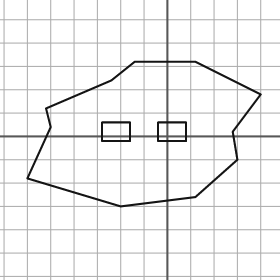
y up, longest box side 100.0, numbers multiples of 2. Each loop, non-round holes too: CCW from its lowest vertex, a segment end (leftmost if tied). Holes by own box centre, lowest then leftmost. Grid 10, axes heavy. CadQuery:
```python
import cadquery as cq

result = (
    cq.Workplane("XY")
    .moveTo(-20.0, -30.0)
    .lineTo(12.0, -26.0)
    .lineTo(30.0, -10.0)
    .lineTo(28.0, 2.0)
    .lineTo(40.0, 18.0)
    .lineTo(12.0, 32.0)
    .lineTo(-14.0, 32.0)
    .lineTo(-24.0, 24.0)
    .lineTo(-52.0, 12.0)
    .lineTo(-50.0, 4.0)
    .lineTo(-60.0, -18.0)
    .close()
    .moveTo(-28.0, -2.0)
    .lineTo(-16.0, -2.0)
    .lineTo(-16.0, 6.0)
    .lineTo(-28.0, 6.0)
    .close()
    .moveTo(-4.0, -2.0)
    .lineTo(8.0, -2.0)
    .lineTo(8.0, 6.0)
    .lineTo(-4.0, 6.0)
    .close()
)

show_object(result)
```